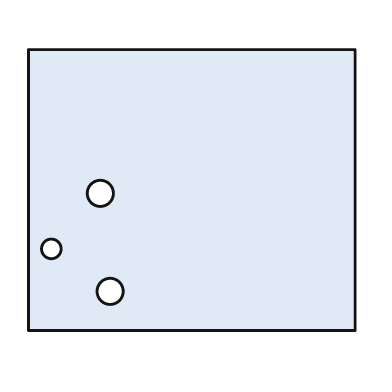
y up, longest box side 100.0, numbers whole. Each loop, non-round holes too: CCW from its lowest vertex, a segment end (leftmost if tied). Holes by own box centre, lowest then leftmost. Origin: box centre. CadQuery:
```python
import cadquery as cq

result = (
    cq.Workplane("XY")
    .moveTo(-50.0, -43.0)
    .lineTo(50.0, -43.0)
    .lineTo(50.0, 43.0)
    .lineTo(-50.0, 43.0)
    .close()
    .moveTo(-25.0, -31.0)
    .circle(4.0)
    .moveTo(-43.0, -18.0)
    .circle(3.0)
    .moveTo(-28.0, -1.0)
    .circle(4.0)
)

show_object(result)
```